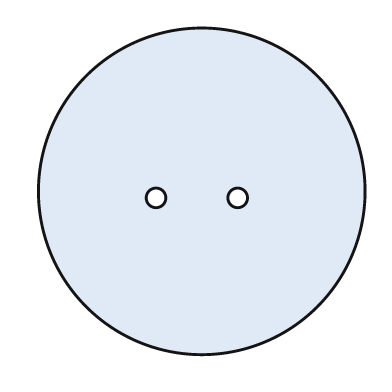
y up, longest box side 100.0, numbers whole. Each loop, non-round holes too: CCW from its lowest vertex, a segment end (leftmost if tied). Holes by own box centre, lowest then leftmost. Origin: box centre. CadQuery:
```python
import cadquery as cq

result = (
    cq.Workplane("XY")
    .moveTo(0.0, 0.0)
    .circle(50.0)
    .moveTo(-14.0, -2.0)
    .circle(3.0)
    .moveTo(11.0, -2.0)
    .circle(3.0)
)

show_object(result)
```